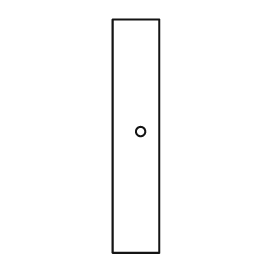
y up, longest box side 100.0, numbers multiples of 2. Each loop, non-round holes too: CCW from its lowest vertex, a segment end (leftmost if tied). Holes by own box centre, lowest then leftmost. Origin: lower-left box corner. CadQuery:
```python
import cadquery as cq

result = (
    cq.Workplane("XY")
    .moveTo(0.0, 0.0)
    .lineTo(20.0, 0.0)
    .lineTo(20.0, 100.0)
    .lineTo(0.0, 100.0)
    .close()
    .moveTo(12.0, 52.0)
    .circle(2.0)
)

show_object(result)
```